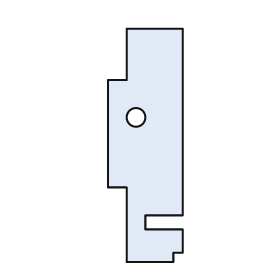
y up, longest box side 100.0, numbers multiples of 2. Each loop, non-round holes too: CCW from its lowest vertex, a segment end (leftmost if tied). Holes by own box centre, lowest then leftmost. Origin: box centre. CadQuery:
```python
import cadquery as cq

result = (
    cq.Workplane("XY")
    .moveTo(-8.0, -50.0)
    .lineTo(12.0, -50.0)
    .lineTo(12.0, -46.0)
    .lineTo(16.0, -46.0)
    .lineTo(16.0, -36.0)
    .lineTo(0.0, -36.0)
    .lineTo(0.0, -30.0)
    .lineTo(16.0, -30.0)
    .lineTo(16.0, 50.0)
    .lineTo(-8.0, 50.0)
    .lineTo(-8.0, 28.0)
    .lineTo(-16.0, 28.0)
    .lineTo(-16.0, -18.0)
    .lineTo(-8.0, -18.0)
    .close()
    .moveTo(-4.0, 12.0)
    .circle(4.0)
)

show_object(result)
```